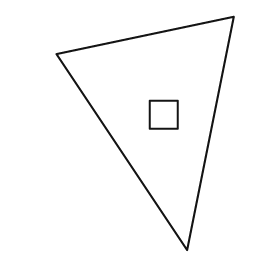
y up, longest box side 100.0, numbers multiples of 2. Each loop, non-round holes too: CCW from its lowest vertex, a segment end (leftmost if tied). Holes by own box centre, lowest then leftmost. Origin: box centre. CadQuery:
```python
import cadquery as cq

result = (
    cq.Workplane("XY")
    .moveTo(18.0, -50.0)
    .lineTo(38.0, 50.0)
    .lineTo(-38.0, 34.0)
    .close()
    .moveTo(2.0, 2.0)
    .lineTo(14.0, 2.0)
    .lineTo(14.0, 14.0)
    .lineTo(2.0, 14.0)
    .close()
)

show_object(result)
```